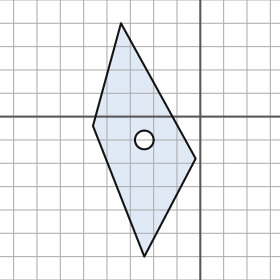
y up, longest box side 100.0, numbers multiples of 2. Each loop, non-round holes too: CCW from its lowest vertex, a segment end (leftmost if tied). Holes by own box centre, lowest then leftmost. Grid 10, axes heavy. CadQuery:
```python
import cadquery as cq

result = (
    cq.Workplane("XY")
    .moveTo(-24.0, -60.0)
    .lineTo(-2.0, -18.0)
    .lineTo(-34.0, 40.0)
    .lineTo(-46.0, -4.0)
    .close()
    .moveTo(-24.0, -10.0)
    .circle(4.0)
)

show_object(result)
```